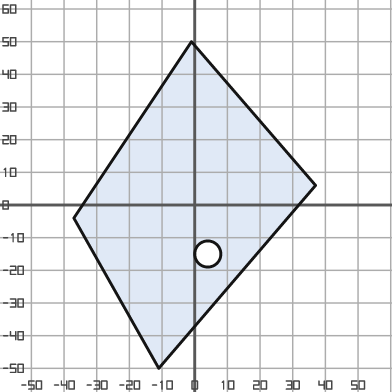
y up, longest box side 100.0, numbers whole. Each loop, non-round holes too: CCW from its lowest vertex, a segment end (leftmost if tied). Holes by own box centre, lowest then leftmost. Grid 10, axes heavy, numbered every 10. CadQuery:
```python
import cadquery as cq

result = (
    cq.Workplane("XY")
    .moveTo(-11.0, -50.0)
    .lineTo(37.0, 6.0)
    .lineTo(-1.0, 50.0)
    .lineTo(-37.0, -4.0)
    .close()
    .moveTo(4.0, -15.0)
    .circle(4.0)
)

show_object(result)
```